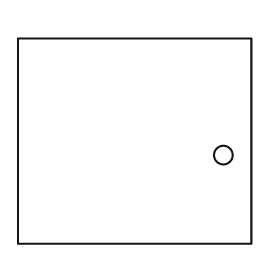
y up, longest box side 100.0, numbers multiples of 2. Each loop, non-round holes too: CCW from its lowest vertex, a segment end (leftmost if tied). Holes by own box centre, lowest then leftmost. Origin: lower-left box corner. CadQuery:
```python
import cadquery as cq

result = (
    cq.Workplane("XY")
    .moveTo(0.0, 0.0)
    .lineTo(100.0, 0.0)
    .lineTo(100.0, 88.0)
    .lineTo(0.0, 88.0)
    .close()
    .moveTo(88.0, 38.0)
    .circle(4.0)
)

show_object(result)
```